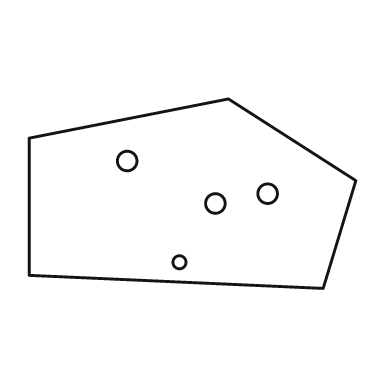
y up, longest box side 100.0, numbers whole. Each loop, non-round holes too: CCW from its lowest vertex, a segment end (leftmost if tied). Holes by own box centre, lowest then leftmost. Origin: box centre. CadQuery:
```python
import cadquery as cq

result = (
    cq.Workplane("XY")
    .moveTo(40.0, -29.0)
    .lineTo(50.0, 4.0)
    .lineTo(11.0, 29.0)
    .lineTo(-50.0, 17.0)
    .lineTo(-50.0, -25.0)
    .close()
    .moveTo(-4.0, -21.0)
    .circle(2.0)
    .moveTo(7.0, -3.0)
    .circle(3.0)
    .moveTo(23.0, 0.0)
    .circle(3.0)
    .moveTo(-20.0, 10.0)
    .circle(3.0)
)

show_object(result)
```